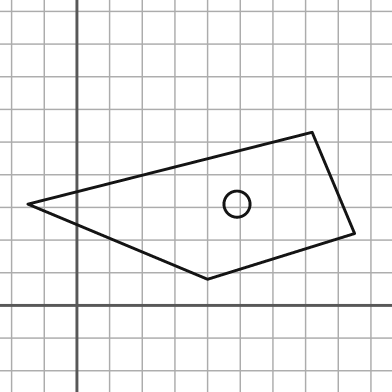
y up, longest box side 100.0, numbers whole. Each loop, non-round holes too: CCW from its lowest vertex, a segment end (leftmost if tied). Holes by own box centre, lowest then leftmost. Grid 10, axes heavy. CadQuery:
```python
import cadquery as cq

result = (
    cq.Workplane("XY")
    .moveTo(40.0, 8.0)
    .lineTo(85.0, 22.0)
    .lineTo(72.0, 53.0)
    .lineTo(-15.0, 31.0)
    .close()
    .moveTo(49.0, 31.0)
    .circle(4.0)
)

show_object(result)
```